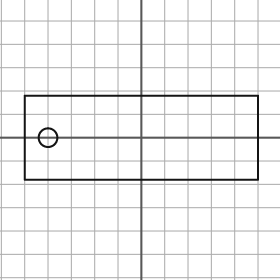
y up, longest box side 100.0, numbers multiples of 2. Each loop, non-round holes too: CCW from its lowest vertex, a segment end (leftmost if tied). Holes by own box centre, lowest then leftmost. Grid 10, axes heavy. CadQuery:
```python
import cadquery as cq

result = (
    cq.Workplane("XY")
    .moveTo(-50.0, -18.0)
    .lineTo(50.0, -18.0)
    .lineTo(50.0, 18.0)
    .lineTo(-50.0, 18.0)
    .close()
    .moveTo(-40.0, 0.0)
    .circle(4.0)
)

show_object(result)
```